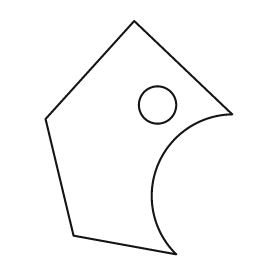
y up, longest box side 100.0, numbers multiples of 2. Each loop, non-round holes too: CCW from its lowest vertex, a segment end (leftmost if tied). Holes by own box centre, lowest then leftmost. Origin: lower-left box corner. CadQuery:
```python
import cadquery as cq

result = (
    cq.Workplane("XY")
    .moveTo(56.0, 0.0)
    .threePointArc((48.0, 38.0), (80.0, 60.0))
    .lineTo(38.0, 100.0)
    .lineTo(0.0, 58.0)
    .lineTo(12.0, 8.0)
    .close()
    .moveTo(48.0, 64.0)
    .circle(8.0)
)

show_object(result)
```